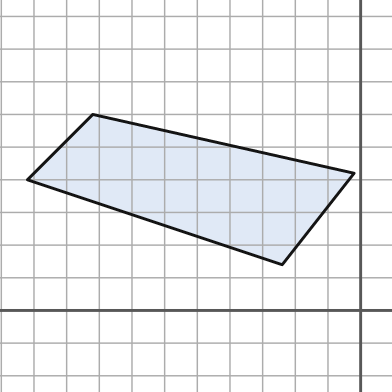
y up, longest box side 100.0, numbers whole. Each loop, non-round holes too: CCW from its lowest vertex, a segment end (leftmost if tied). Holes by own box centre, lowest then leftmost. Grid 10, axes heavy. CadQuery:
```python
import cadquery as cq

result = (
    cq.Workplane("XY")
    .moveTo(-24.0, 14.0)
    .lineTo(-2.0, 42.0)
    .lineTo(-82.0, 60.0)
    .lineTo(-102.0, 40.0)
    .close()
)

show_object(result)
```